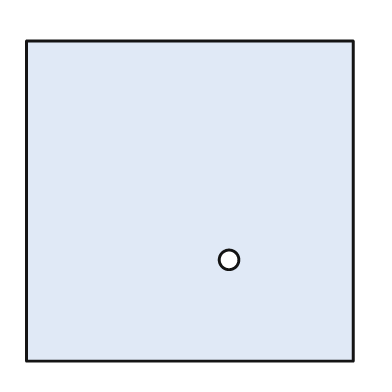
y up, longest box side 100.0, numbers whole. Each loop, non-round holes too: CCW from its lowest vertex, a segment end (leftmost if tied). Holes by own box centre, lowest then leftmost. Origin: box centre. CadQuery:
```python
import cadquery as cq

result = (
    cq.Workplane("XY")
    .moveTo(-50.0, -49.0)
    .lineTo(50.0, -49.0)
    .lineTo(50.0, 49.0)
    .lineTo(-50.0, 49.0)
    .close()
    .moveTo(12.0, -18.0)
    .circle(3.0)
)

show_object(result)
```